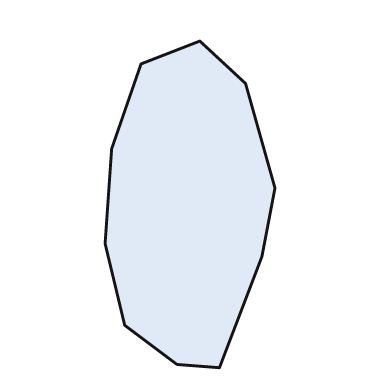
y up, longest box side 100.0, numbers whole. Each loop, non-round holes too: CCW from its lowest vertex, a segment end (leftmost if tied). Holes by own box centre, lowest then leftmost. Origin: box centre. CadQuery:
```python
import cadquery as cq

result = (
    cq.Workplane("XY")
    .moveTo(9.0, -50.0)
    .lineTo(22.0, -16.0)
    .lineTo(26.0, 5.0)
    .lineTo(17.0, 37.0)
    .lineTo(3.0, 50.0)
    .lineTo(-15.0, 43.0)
    .lineTo(-24.0, 17.0)
    .lineTo(-26.0, -12.0)
    .lineTo(-20.0, -37.0)
    .lineTo(-4.0, -49.0)
    .close()
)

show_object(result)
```